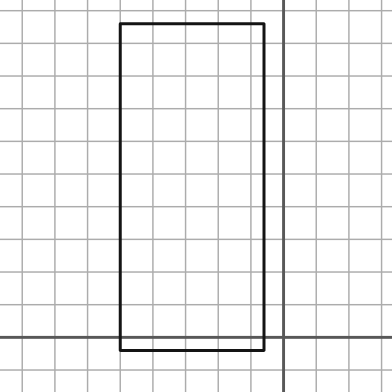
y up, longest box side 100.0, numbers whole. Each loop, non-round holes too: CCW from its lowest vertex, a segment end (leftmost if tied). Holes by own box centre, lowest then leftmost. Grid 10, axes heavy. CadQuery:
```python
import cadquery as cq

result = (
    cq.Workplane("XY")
    .moveTo(-50.0, -4.0)
    .lineTo(-6.0, -4.0)
    .lineTo(-6.0, 96.0)
    .lineTo(-50.0, 96.0)
    .close()
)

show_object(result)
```